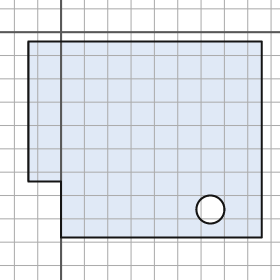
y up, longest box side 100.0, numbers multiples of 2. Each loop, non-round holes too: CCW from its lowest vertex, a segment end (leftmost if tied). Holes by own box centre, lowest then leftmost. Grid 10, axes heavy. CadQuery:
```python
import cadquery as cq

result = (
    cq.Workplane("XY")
    .moveTo(0.0, -88.0)
    .lineTo(86.0, -88.0)
    .lineTo(86.0, -4.0)
    .lineTo(-14.0, -4.0)
    .lineTo(-14.0, -64.0)
    .lineTo(0.0, -64.0)
    .close()
    .moveTo(64.0, -76.0)
    .circle(6.0)
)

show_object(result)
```